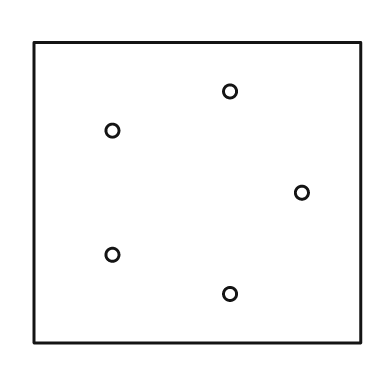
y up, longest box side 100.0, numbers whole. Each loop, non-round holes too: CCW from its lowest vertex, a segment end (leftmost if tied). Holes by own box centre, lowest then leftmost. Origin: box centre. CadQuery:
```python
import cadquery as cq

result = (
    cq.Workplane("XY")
    .moveTo(-50.0, -46.0)
    .lineTo(50.0, -46.0)
    .lineTo(50.0, 46.0)
    .lineTo(-50.0, 46.0)
    .close()
    .moveTo(10.0, -31.0)
    .circle(2.0)
    .moveTo(-26.0, -19.0)
    .circle(2.0)
    .moveTo(32.0, 0.0)
    .circle(2.0)
    .moveTo(-26.0, 19.0)
    .circle(2.0)
    .moveTo(10.0, 31.0)
    .circle(2.0)
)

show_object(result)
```